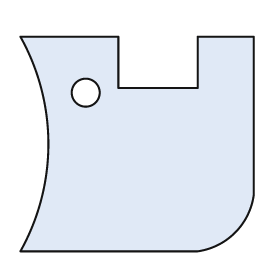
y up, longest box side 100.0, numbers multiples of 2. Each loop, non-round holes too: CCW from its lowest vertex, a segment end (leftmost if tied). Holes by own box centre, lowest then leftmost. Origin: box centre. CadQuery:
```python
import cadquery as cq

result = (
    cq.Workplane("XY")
    .moveTo(-50.0, -46.0)
    .lineTo(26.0, -46.0)
    .threePointArc((42.0, -38.0), (50.0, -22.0))
    .lineTo(50.0, 46.0)
    .lineTo(26.0, 46.0)
    .lineTo(26.0, 24.0)
    .lineTo(-8.0, 24.0)
    .lineTo(-8.0, 46.0)
    .lineTo(-50.0, 46.0)
    .threePointArc((-38.0, 0.0), (-50.0, -46.0))
    .close()
    .moveTo(-22.0, 22.0)
    .circle(6.0)
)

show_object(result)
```